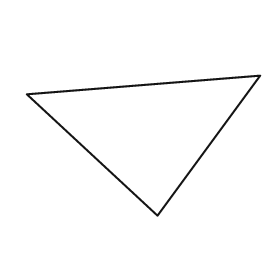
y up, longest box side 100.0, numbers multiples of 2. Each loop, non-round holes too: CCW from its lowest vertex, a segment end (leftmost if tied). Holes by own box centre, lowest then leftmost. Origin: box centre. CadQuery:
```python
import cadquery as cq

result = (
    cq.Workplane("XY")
    .moveTo(6.0, -30.0)
    .lineTo(50.0, 30.0)
    .lineTo(-50.0, 22.0)
    .close()
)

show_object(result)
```